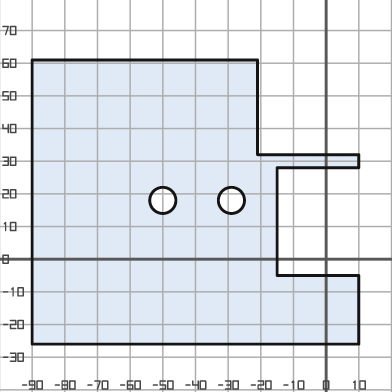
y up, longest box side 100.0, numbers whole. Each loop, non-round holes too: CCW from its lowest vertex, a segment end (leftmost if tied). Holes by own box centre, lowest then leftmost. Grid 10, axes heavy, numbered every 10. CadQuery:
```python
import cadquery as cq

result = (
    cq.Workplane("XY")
    .moveTo(-90.0, -26.0)
    .lineTo(10.0, -26.0)
    .lineTo(10.0, -5.0)
    .lineTo(-15.0, -5.0)
    .lineTo(-15.0, 28.0)
    .lineTo(10.0, 28.0)
    .lineTo(10.0, 32.0)
    .lineTo(-21.0, 32.0)
    .lineTo(-21.0, 61.0)
    .lineTo(-90.0, 61.0)
    .close()
    .moveTo(-50.0, 18.0)
    .circle(4.0)
    .moveTo(-29.0, 18.0)
    .circle(4.0)
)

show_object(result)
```